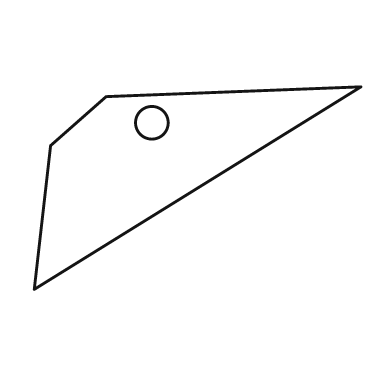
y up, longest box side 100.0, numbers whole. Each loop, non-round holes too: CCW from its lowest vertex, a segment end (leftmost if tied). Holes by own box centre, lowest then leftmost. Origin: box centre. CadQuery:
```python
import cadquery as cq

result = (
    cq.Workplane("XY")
    .moveTo(-50.0, -31.0)
    .lineTo(50.0, 31.0)
    .lineTo(-28.0, 28.0)
    .lineTo(-45.0, 13.0)
    .close()
    .moveTo(-14.0, 20.0)
    .circle(5.0)
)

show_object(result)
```